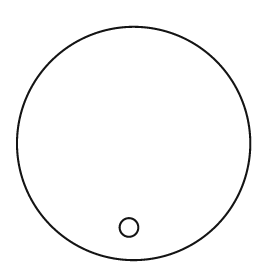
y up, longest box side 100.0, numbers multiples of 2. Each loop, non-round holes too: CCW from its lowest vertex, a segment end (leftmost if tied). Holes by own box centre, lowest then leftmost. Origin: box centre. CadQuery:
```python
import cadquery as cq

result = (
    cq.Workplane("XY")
    .moveTo(0.0, 0.0)
    .circle(50.0)
    .moveTo(-2.0, -36.0)
    .circle(4.0)
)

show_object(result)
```